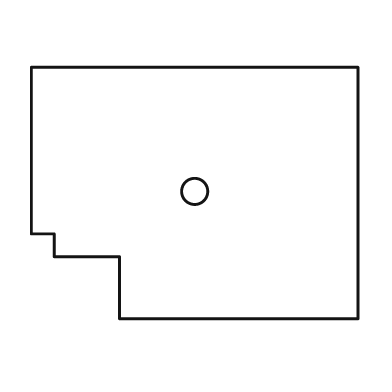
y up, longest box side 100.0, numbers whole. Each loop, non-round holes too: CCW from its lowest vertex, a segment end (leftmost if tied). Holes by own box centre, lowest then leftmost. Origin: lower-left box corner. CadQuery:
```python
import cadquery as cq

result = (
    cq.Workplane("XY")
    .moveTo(27.0, 0.0)
    .lineTo(100.0, 0.0)
    .lineTo(100.0, 77.0)
    .lineTo(0.0, 77.0)
    .lineTo(0.0, 26.0)
    .lineTo(7.0, 26.0)
    .lineTo(7.0, 19.0)
    .lineTo(27.0, 19.0)
    .close()
    .moveTo(50.0, 39.0)
    .circle(4.0)
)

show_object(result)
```